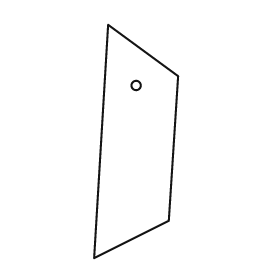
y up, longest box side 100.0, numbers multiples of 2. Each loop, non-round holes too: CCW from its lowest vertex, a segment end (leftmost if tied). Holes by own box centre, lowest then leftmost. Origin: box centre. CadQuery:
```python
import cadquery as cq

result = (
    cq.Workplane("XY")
    .moveTo(-18.0, -50.0)
    .lineTo(14.0, -34.0)
    .lineTo(18.0, 28.0)
    .lineTo(-12.0, 50.0)
    .close()
    .moveTo(0.0, 24.0)
    .circle(2.0)
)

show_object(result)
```